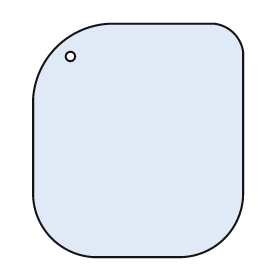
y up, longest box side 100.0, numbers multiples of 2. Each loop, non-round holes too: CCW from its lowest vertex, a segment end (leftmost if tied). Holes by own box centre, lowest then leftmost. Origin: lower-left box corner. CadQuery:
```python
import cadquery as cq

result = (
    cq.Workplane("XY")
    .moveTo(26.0, 0.0)
    .lineTo(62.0, 0.0)
    .threePointArc((82.0, 8.0), (90.0, 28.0))
    .lineTo(90.0, 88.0)
    .threePointArc((86.0, 96.0), (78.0, 100.0))
    .lineTo(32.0, 100.0)
    .threePointArc((10.0, 90.0), (0.0, 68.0))
    .lineTo(0.0, 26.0)
    .threePointArc((8.0, 8.0), (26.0, 0.0))
    .close()
    .moveTo(16.0, 86.0)
    .circle(2.0)
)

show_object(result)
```